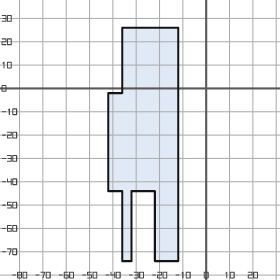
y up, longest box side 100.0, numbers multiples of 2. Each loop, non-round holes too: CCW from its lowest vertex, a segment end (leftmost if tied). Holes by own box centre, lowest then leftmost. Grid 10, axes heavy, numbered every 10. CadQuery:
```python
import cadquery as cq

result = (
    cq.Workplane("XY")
    .moveTo(-36.0, -74.0)
    .lineTo(-32.0, -74.0)
    .lineTo(-32.0, -44.0)
    .lineTo(-22.0, -44.0)
    .lineTo(-22.0, -74.0)
    .lineTo(-12.0, -74.0)
    .lineTo(-12.0, 26.0)
    .lineTo(-36.0, 26.0)
    .lineTo(-36.0, -2.0)
    .lineTo(-42.0, -2.0)
    .lineTo(-42.0, -44.0)
    .lineTo(-36.0, -44.0)
    .close()
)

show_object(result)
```